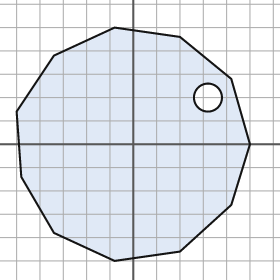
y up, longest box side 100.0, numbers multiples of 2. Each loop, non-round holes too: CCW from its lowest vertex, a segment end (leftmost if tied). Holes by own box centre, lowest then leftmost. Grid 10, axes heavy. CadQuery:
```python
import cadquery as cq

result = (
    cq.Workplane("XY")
    .moveTo(-8.0, -50.0)
    .lineTo(20.0, -46.0)
    .lineTo(42.0, -26.0)
    .lineTo(50.0, 0.0)
    .lineTo(42.0, 28.0)
    .lineTo(20.0, 46.0)
    .lineTo(-8.0, 50.0)
    .lineTo(-34.0, 38.0)
    .lineTo(-50.0, 14.0)
    .lineTo(-48.0, -14.0)
    .lineTo(-34.0, -38.0)
    .close()
    .moveTo(32.0, 20.0)
    .circle(6.0)
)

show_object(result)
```